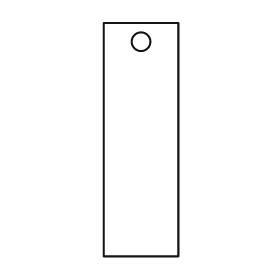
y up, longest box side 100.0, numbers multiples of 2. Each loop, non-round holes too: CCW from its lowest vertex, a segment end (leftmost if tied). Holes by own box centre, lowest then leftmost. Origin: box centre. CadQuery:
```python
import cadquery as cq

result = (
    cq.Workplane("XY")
    .moveTo(-16.0, -50.0)
    .lineTo(16.0, -50.0)
    .lineTo(16.0, 50.0)
    .lineTo(-16.0, 50.0)
    .close()
    .moveTo(0.0, 42.0)
    .circle(4.0)
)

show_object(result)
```